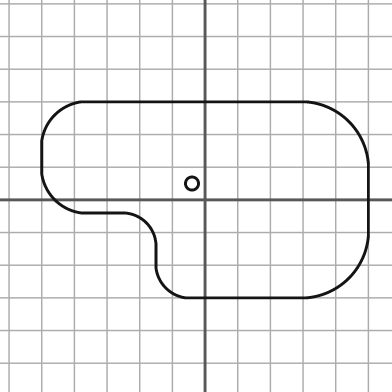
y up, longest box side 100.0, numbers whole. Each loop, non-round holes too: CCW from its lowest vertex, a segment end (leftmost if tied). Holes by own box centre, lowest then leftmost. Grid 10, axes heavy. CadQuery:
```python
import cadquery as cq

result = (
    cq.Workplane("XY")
    .moveTo(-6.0, -30.0)
    .lineTo(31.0, -30.0)
    .threePointArc((44.0, -24.0), (50.0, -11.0))
    .lineTo(50.0, 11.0)
    .threePointArc((44.0, 24.0), (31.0, 30.0))
    .lineTo(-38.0, 30.0)
    .threePointArc((-46.0, 26.0), (-50.0, 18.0))
    .lineTo(-50.0, 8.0)
    .threePointArc((-46.0, 0.0), (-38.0, -4.0))
    .lineTo(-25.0, -4.0)
    .threePointArc((-18.0, -7.0), (-15.0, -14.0))
    .lineTo(-15.0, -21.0)
    .threePointArc((-12.0, -27.0), (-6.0, -30.0))
    .close()
    .moveTo(-4.0, 5.0)
    .circle(2.0)
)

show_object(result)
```